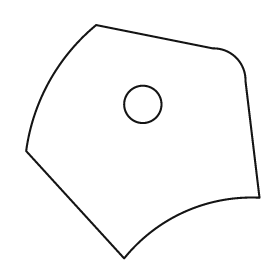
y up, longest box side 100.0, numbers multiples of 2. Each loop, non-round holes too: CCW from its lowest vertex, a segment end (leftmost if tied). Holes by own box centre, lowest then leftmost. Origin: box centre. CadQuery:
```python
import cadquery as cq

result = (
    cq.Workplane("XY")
    .moveTo(-8.0, -50.0)
    .threePointArc((18.0, -30.0), (50.0, -24.0))
    .lineTo(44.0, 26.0)
    .threePointArc((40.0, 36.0), (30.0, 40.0))
    .lineTo(-20.0, 50.0)
    .threePointArc((-40.0, 26.0), (-50.0, -4.0))
    .close()
    .moveTo(0.0, 16.0)
    .circle(8.0)
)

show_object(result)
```